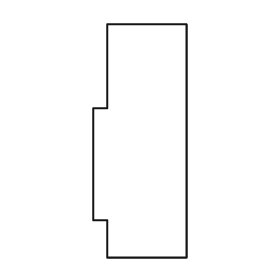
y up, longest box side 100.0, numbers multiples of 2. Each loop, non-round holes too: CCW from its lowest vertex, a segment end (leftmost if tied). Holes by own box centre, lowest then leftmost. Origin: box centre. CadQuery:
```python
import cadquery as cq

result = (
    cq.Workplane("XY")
    .moveTo(-14.0, -50.0)
    .lineTo(20.0, -50.0)
    .lineTo(20.0, 50.0)
    .lineTo(-14.0, 50.0)
    .lineTo(-14.0, 14.0)
    .lineTo(-20.0, 14.0)
    .lineTo(-20.0, -34.0)
    .lineTo(-14.0, -34.0)
    .close()
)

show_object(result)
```